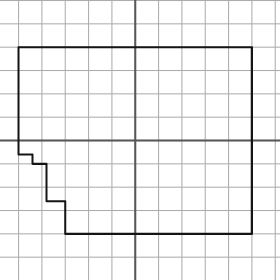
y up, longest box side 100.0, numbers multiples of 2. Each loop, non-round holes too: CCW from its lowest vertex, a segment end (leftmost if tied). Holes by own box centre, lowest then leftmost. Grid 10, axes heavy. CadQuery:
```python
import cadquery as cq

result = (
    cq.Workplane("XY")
    .moveTo(-30.0, -40.0)
    .lineTo(50.0, -40.0)
    .lineTo(50.0, 40.0)
    .lineTo(-50.0, 40.0)
    .lineTo(-50.0, -6.0)
    .lineTo(-44.0, -6.0)
    .lineTo(-44.0, -10.0)
    .lineTo(-38.0, -10.0)
    .lineTo(-38.0, -26.0)
    .lineTo(-30.0, -26.0)
    .close()
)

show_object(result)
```